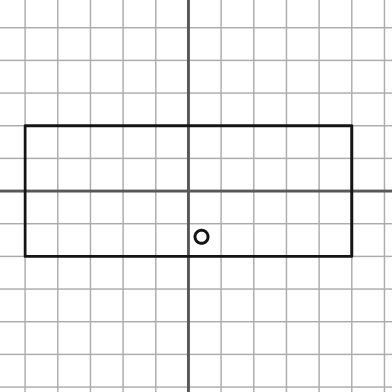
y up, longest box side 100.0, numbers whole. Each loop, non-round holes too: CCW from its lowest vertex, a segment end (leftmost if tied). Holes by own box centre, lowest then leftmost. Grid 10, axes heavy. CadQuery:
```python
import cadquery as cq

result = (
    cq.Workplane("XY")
    .moveTo(-50.0, -20.0)
    .lineTo(50.0, -20.0)
    .lineTo(50.0, 20.0)
    .lineTo(-50.0, 20.0)
    .close()
    .moveTo(4.0, -14.0)
    .circle(2.0)
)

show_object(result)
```